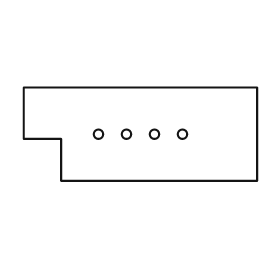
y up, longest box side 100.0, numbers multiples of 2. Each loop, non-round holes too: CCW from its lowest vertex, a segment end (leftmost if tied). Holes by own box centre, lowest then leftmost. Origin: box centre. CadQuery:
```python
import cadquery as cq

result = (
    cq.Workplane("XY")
    .moveTo(-34.0, -20.0)
    .lineTo(50.0, -20.0)
    .lineTo(50.0, 20.0)
    .lineTo(-50.0, 20.0)
    .lineTo(-50.0, -2.0)
    .lineTo(-34.0, -2.0)
    .close()
    .moveTo(-18.0, 0.0)
    .circle(2.0)
    .moveTo(-6.0, 0.0)
    .circle(2.0)
    .moveTo(6.0, 0.0)
    .circle(2.0)
    .moveTo(18.0, 0.0)
    .circle(2.0)
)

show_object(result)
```